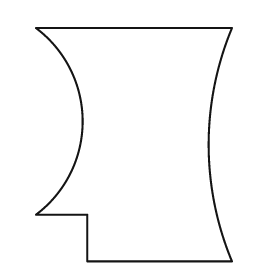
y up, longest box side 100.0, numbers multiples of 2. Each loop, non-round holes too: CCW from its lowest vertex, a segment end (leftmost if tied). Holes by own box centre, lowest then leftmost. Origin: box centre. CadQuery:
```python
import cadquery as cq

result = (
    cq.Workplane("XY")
    .moveTo(-20.0, -50.0)
    .lineTo(42.0, -50.0)
    .threePointArc((32.0, 0.0), (42.0, 50.0))
    .lineTo(-42.0, 50.0)
    .threePointArc((-22.0, 10.0), (-42.0, -30.0))
    .lineTo(-20.0, -30.0)
    .close()
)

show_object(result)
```